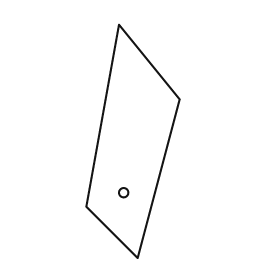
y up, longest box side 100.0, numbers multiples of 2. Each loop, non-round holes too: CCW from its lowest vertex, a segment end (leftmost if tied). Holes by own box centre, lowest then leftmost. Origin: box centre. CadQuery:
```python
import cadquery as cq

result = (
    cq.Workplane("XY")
    .moveTo(2.0, -50.0)
    .lineTo(20.0, 18.0)
    .lineTo(-6.0, 50.0)
    .lineTo(-20.0, -28.0)
    .close()
    .moveTo(-4.0, -22.0)
    .circle(2.0)
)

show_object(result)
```